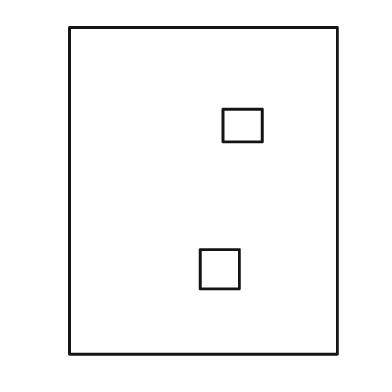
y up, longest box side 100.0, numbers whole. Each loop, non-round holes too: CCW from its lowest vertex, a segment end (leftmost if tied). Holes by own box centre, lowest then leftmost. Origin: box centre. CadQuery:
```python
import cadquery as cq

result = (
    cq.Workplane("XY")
    .moveTo(-41.0, -50.0)
    .lineTo(41.0, -50.0)
    .lineTo(41.0, 50.0)
    .lineTo(-41.0, 50.0)
    .close()
    .moveTo(-1.0, -30.0)
    .lineTo(11.0, -30.0)
    .lineTo(11.0, -18.0)
    .lineTo(-1.0, -18.0)
    .close()
    .moveTo(6.0, 15.0)
    .lineTo(18.0, 15.0)
    .lineTo(18.0, 25.0)
    .lineTo(6.0, 25.0)
    .close()
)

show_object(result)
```